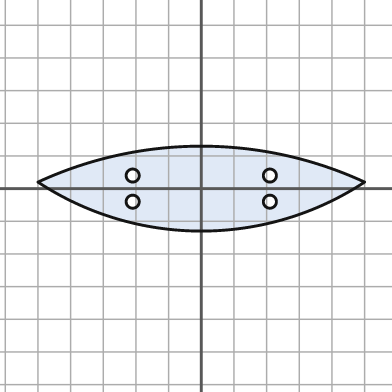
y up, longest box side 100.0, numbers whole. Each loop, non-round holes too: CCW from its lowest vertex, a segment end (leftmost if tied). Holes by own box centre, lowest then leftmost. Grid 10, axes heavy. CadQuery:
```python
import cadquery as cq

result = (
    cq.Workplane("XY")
    .moveTo(-50.0, 2.0)
    .threePointArc((0.0, -13.0), (50.0, 2.0))
    .threePointArc((0.0, 13.0), (-50.0, 2.0))
    .close()
    .moveTo(-21.0, -4.0)
    .circle(2.0)
    .moveTo(21.0, -4.0)
    .circle(2.0)
    .moveTo(-21.0, 4.0)
    .circle(2.0)
    .moveTo(21.0, 4.0)
    .circle(2.0)
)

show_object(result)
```